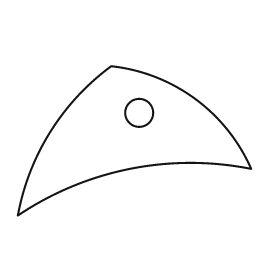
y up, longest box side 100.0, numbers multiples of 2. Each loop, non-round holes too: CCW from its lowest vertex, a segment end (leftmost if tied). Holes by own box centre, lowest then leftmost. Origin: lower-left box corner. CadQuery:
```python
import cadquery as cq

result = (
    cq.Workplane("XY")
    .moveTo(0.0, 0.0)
    .threePointArc((48.0, 20.0), (100.0, 20.0))
    .threePointArc((76.0, 50.0), (40.0, 64.0))
    .threePointArc((14.0, 36.0), (0.0, 0.0))
    .close()
    .moveTo(52.0, 44.0)
    .circle(6.0)
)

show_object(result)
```